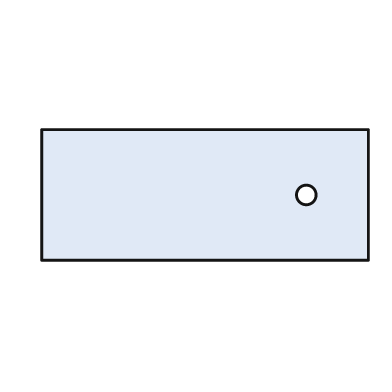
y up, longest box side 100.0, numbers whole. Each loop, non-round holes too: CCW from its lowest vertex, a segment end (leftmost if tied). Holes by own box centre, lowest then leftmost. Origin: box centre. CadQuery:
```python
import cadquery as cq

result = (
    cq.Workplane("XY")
    .moveTo(-50.0, -20.0)
    .lineTo(50.0, -20.0)
    .lineTo(50.0, 20.0)
    .lineTo(-50.0, 20.0)
    .close()
    .moveTo(31.0, 0.0)
    .circle(3.0)
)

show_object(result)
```